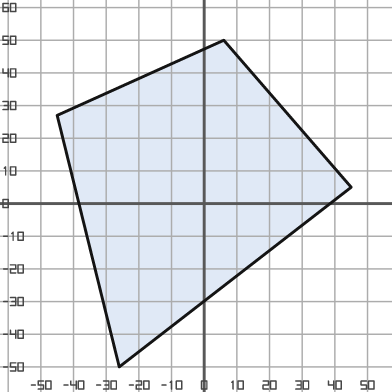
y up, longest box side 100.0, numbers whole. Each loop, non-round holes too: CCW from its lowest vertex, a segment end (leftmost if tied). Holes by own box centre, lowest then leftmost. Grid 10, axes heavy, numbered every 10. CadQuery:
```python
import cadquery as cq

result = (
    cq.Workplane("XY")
    .moveTo(-26.0, -50.0)
    .lineTo(45.0, 5.0)
    .lineTo(6.0, 50.0)
    .lineTo(-45.0, 27.0)
    .close()
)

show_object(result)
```